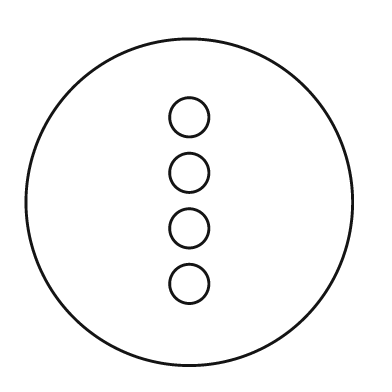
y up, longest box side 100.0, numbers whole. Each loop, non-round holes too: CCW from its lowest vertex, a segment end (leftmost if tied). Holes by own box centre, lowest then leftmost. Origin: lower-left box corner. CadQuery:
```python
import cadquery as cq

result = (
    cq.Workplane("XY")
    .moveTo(50.0, 50.0)
    .circle(50.0)
    .moveTo(50.0, 25.0)
    .circle(6.0)
    .moveTo(50.0, 42.0)
    .circle(6.0)
    .moveTo(50.0, 59.0)
    .circle(6.0)
    .moveTo(50.0, 76.0)
    .circle(6.0)
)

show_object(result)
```